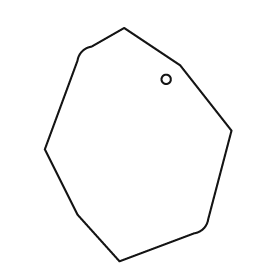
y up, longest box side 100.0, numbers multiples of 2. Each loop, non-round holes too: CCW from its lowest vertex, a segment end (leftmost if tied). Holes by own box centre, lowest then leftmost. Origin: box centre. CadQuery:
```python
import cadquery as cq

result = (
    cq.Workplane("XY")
    .moveTo(-8.0, -50.0)
    .lineTo(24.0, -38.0)
    .threePointArc((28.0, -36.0), (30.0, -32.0))
    .lineTo(40.0, 6.0)
    .lineTo(18.0, 34.0)
    .lineTo(-6.0, 50.0)
    .lineTo(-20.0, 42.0)
    .threePointArc((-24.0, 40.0), (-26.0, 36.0))
    .lineTo(-40.0, -2.0)
    .lineTo(-26.0, -30.0)
    .close()
    .moveTo(12.0, 28.0)
    .circle(2.0)
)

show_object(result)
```